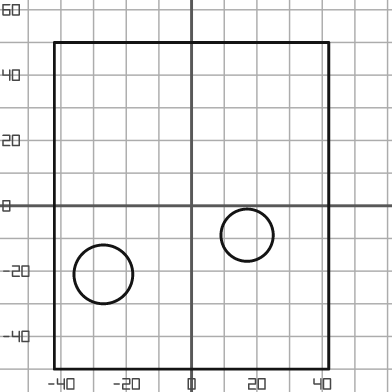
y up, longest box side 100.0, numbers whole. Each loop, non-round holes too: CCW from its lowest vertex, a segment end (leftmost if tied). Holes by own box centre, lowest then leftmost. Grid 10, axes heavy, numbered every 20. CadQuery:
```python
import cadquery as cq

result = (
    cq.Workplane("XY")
    .moveTo(-42.0, -50.0)
    .lineTo(42.0, -50.0)
    .lineTo(42.0, 50.0)
    .lineTo(-42.0, 50.0)
    .close()
    .moveTo(-27.0, -21.0)
    .circle(9.0)
    .moveTo(17.0, -9.0)
    .circle(8.0)
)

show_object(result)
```